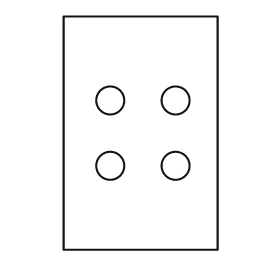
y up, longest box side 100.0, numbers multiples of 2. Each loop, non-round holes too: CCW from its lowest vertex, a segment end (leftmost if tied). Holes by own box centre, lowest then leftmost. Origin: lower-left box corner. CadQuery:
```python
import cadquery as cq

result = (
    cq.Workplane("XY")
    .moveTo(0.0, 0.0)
    .lineTo(66.0, 0.0)
    .lineTo(66.0, 100.0)
    .lineTo(0.0, 100.0)
    .close()
    .moveTo(20.0, 36.0)
    .circle(6.0)
    .moveTo(48.0, 36.0)
    .circle(6.0)
    .moveTo(20.0, 64.0)
    .circle(6.0)
    .moveTo(48.0, 64.0)
    .circle(6.0)
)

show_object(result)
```